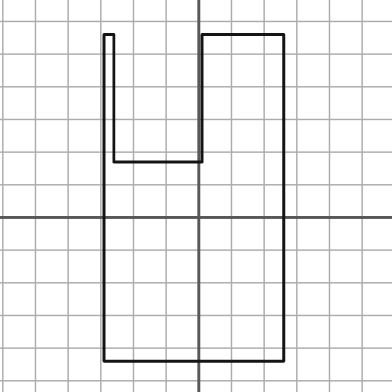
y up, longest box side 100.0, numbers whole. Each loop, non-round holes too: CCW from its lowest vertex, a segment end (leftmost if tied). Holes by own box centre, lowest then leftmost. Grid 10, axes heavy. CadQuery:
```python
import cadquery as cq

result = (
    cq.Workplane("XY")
    .moveTo(-29.0, -44.0)
    .lineTo(26.0, -44.0)
    .lineTo(26.0, 56.0)
    .lineTo(1.0, 56.0)
    .lineTo(1.0, 17.0)
    .lineTo(-26.0, 17.0)
    .lineTo(-26.0, 56.0)
    .lineTo(-29.0, 56.0)
    .close()
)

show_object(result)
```